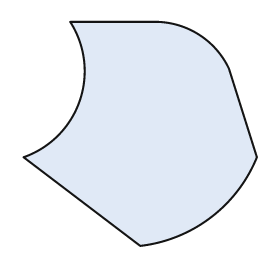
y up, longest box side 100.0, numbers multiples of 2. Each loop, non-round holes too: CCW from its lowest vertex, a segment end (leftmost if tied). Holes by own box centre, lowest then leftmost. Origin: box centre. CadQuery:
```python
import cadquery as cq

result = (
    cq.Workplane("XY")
    .moveTo(0.0, -48.0)
    .threePointArc((30.0, -36.0), (50.0, -10.0))
    .lineTo(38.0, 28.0)
    .threePointArc((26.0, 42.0), (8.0, 48.0))
    .lineTo(-30.0, 48.0)
    .threePointArc((-26.0, 14.0), (-50.0, -10.0))
    .close()
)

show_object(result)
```